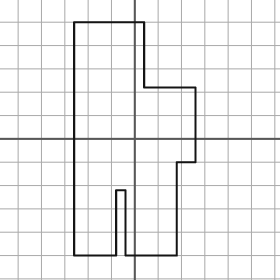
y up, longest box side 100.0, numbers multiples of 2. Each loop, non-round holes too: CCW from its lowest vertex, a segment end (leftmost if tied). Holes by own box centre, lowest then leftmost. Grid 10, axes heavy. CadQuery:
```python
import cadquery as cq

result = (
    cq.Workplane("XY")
    .moveTo(-26.0, -50.0)
    .lineTo(-8.0, -50.0)
    .lineTo(-8.0, -22.0)
    .lineTo(-4.0, -22.0)
    .lineTo(-4.0, -50.0)
    .lineTo(18.0, -50.0)
    .lineTo(18.0, -10.0)
    .lineTo(26.0, -10.0)
    .lineTo(26.0, 22.0)
    .lineTo(4.0, 22.0)
    .lineTo(4.0, 50.0)
    .lineTo(-26.0, 50.0)
    .close()
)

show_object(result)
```